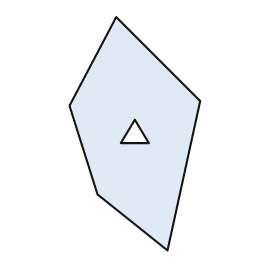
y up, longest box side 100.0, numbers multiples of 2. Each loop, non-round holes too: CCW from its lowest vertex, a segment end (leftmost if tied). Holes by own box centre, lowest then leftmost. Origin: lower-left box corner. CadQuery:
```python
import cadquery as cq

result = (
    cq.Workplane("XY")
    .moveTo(42.0, 0.0)
    .lineTo(56.0, 64.0)
    .lineTo(20.0, 100.0)
    .lineTo(0.0, 62.0)
    .lineTo(12.0, 24.0)
    .close()
    .moveTo(22.0, 46.0)
    .lineTo(34.0, 46.0)
    .lineTo(28.0, 56.0)
    .close()
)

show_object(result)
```